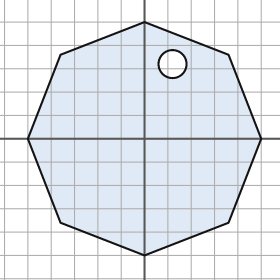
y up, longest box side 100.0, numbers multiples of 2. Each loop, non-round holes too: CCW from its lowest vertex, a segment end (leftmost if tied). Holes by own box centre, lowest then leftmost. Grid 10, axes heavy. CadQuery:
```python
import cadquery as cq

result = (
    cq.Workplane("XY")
    .moveTo(0.0, -50.0)
    .lineTo(36.0, -36.0)
    .lineTo(50.0, 0.0)
    .lineTo(36.0, 36.0)
    .lineTo(0.0, 50.0)
    .lineTo(-36.0, 36.0)
    .lineTo(-50.0, 0.0)
    .lineTo(-36.0, -36.0)
    .close()
    .moveTo(12.0, 32.0)
    .circle(6.0)
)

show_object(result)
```